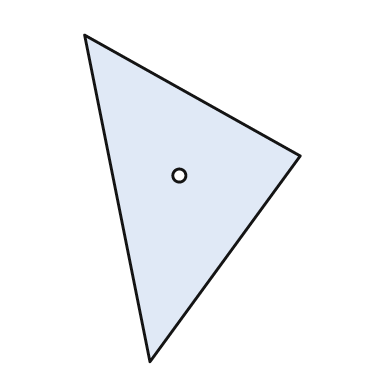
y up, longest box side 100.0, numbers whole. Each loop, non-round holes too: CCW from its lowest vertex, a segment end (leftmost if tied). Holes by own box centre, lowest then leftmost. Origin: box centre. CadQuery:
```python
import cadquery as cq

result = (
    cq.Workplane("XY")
    .moveTo(-13.0, -50.0)
    .lineTo(33.0, 13.0)
    .lineTo(-33.0, 50.0)
    .close()
    .moveTo(-4.0, 7.0)
    .circle(2.0)
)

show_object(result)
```